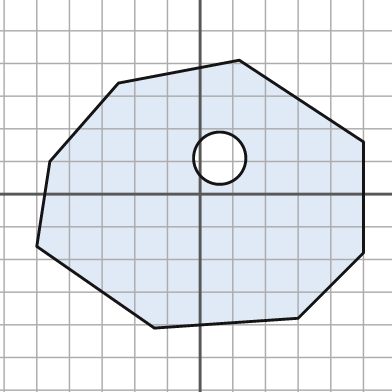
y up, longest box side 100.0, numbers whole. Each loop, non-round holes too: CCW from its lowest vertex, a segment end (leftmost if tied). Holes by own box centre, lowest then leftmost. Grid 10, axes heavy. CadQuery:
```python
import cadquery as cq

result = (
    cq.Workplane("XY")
    .moveTo(-14.0, -41.0)
    .lineTo(30.0, -38.0)
    .lineTo(50.0, -18.0)
    .lineTo(50.0, 16.0)
    .lineTo(12.0, 41.0)
    .lineTo(-25.0, 34.0)
    .lineTo(-46.0, 10.0)
    .lineTo(-50.0, -16.0)
    .close()
    .moveTo(6.0, 11.0)
    .circle(8.0)
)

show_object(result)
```